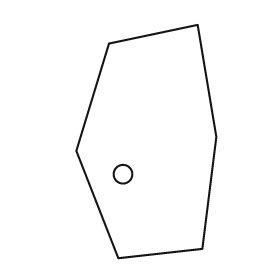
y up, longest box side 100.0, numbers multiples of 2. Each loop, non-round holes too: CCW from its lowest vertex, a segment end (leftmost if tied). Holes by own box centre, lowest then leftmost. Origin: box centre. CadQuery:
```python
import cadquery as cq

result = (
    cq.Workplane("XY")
    .moveTo(-12.0, -50.0)
    .lineTo(24.0, -46.0)
    .lineTo(30.0, 2.0)
    .lineTo(22.0, 50.0)
    .lineTo(-16.0, 42.0)
    .lineTo(-30.0, -4.0)
    .close()
    .moveTo(-10.0, -14.0)
    .circle(4.0)
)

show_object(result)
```